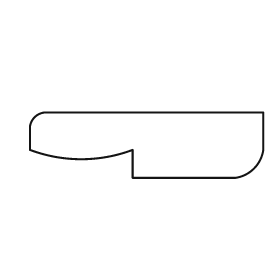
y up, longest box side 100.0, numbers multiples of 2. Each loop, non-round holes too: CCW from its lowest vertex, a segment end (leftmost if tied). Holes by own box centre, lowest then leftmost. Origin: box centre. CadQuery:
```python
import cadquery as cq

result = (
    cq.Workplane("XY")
    .moveTo(-6.0, -14.0)
    .lineTo(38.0, -14.0)
    .threePointArc((46.0, -10.0), (50.0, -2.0))
    .lineTo(50.0, 14.0)
    .lineTo(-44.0, 14.0)
    .threePointArc((-48.0, 12.0), (-50.0, 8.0))
    .lineTo(-50.0, -2.0)
    .threePointArc((-28.0, -6.0), (-6.0, -2.0))
    .close()
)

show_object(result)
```